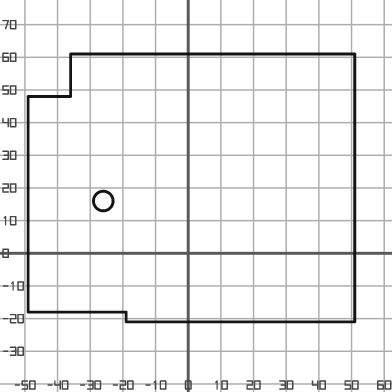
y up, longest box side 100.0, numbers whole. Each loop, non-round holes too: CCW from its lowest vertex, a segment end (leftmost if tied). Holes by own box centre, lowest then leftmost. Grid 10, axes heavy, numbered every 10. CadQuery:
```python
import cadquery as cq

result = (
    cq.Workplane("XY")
    .moveTo(-19.0, -21.0)
    .lineTo(51.0, -21.0)
    .lineTo(51.0, 61.0)
    .lineTo(-36.0, 61.0)
    .lineTo(-36.0, 48.0)
    .lineTo(-49.0, 48.0)
    .lineTo(-49.0, -18.0)
    .lineTo(-19.0, -18.0)
    .close()
    .moveTo(-26.0, 16.0)
    .circle(3.0)
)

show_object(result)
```